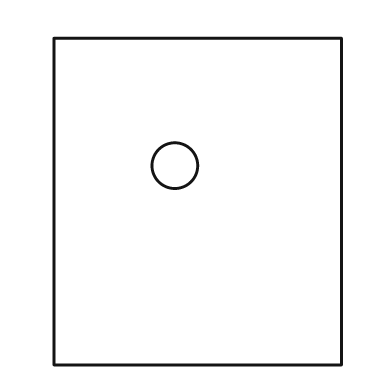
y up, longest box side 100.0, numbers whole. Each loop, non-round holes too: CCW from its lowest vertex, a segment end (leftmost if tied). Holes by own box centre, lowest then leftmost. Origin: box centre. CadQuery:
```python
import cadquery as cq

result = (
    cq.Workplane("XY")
    .moveTo(-44.0, -50.0)
    .lineTo(44.0, -50.0)
    .lineTo(44.0, 50.0)
    .lineTo(-44.0, 50.0)
    .close()
    .moveTo(-7.0, 11.0)
    .circle(7.0)
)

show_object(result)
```